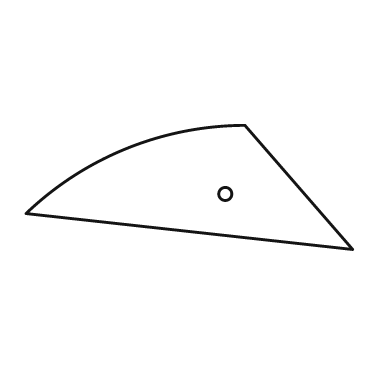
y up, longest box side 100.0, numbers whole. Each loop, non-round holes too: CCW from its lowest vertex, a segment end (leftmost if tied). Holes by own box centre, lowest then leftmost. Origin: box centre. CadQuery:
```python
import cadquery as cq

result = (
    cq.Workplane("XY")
    .moveTo(50.0, -19.0)
    .lineTo(17.0, 19.0)
    .threePointArc((-19.0, 12.0), (-50.0, -8.0))
    .close()
    .moveTo(11.0, -2.0)
    .circle(2.0)
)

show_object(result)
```